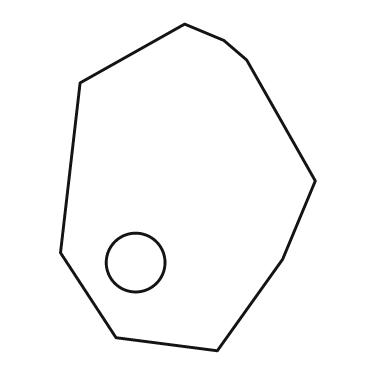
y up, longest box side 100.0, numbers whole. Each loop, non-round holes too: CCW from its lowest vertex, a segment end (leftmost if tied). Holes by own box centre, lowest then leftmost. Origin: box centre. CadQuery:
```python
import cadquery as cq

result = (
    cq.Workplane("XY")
    .moveTo(9.0, -50.0)
    .lineTo(29.0, -22.0)
    .lineTo(39.0, 2.0)
    .lineTo(18.0, 39.0)
    .lineTo(11.0, 45.0)
    .lineTo(-1.0, 50.0)
    .lineTo(-33.0, 32.0)
    .lineTo(-39.0, -20.0)
    .lineTo(-22.0, -46.0)
    .close()
    .moveTo(-16.0, -23.0)
    .circle(9.0)
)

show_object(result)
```